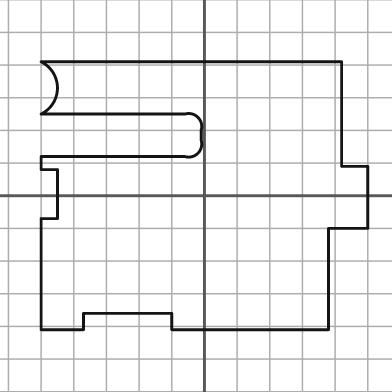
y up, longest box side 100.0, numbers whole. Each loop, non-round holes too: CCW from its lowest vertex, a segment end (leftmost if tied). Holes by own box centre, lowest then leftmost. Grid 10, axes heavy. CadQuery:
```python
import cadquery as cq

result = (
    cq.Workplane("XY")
    .moveTo(-50.0, -41.0)
    .lineTo(-37.0, -41.0)
    .lineTo(-37.0, -36.0)
    .lineTo(-10.0, -36.0)
    .lineTo(-10.0, -41.0)
    .lineTo(38.0, -41.0)
    .lineTo(38.0, -10.0)
    .lineTo(50.0, -10.0)
    .lineTo(50.0, 9.0)
    .lineTo(42.0, 9.0)
    .lineTo(42.0, 41.0)
    .lineTo(-50.0, 41.0)
    .threePointArc((-45.0, 33.0), (-50.0, 25.0))
    .lineTo(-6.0, 25.0)
    .threePointArc((-2.0, 24.0), (-1.0, 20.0))
    .lineTo(-1.0, 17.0)
    .threePointArc((-2.0, 13.0), (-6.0, 12.0))
    .lineTo(-50.0, 12.0)
    .lineTo(-50.0, 8.0)
    .lineTo(-45.0, 8.0)
    .lineTo(-45.0, -7.0)
    .lineTo(-50.0, -7.0)
    .close()
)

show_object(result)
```